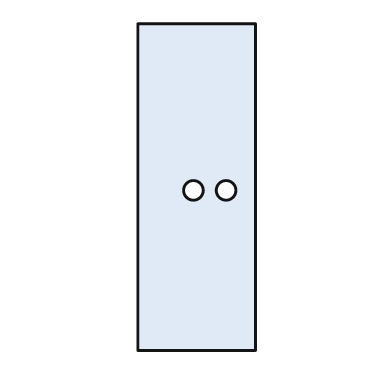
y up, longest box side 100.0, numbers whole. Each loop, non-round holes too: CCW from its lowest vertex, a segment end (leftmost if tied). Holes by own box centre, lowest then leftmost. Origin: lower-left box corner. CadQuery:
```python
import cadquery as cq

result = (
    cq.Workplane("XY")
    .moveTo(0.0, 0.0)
    .lineTo(36.0, 0.0)
    .lineTo(36.0, 100.0)
    .lineTo(0.0, 100.0)
    .close()
    .moveTo(17.0, 49.0)
    .circle(3.0)
    .moveTo(27.0, 49.0)
    .circle(3.0)
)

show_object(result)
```